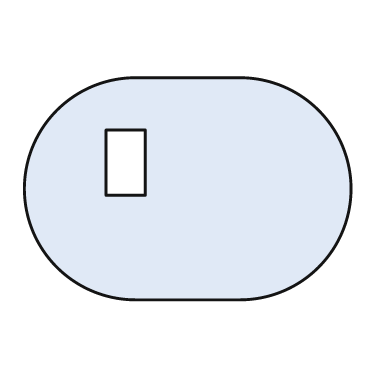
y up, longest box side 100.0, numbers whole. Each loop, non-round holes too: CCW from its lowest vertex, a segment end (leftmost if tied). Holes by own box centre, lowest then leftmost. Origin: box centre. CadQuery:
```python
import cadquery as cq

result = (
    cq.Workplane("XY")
    .moveTo(-16.0, -34.0)
    .lineTo(16.0, -34.0)
    .threePointArc((50.0, 0.0), (16.0, 34.0))
    .lineTo(-16.0, 34.0)
    .threePointArc((-50.0, 0.0), (-16.0, -34.0))
    .close()
    .moveTo(-25.0, -2.0)
    .lineTo(-13.0, -2.0)
    .lineTo(-13.0, 18.0)
    .lineTo(-25.0, 18.0)
    .close()
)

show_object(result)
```